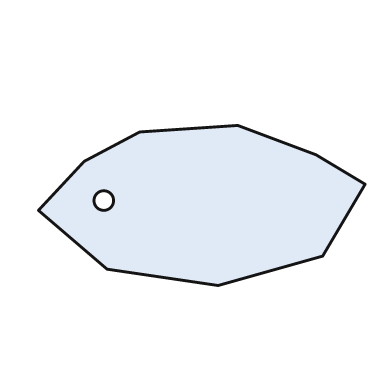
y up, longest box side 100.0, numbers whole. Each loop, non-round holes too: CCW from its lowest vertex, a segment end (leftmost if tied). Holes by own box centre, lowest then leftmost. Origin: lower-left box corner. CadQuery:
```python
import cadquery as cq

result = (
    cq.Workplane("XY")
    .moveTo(55.0, 0.0)
    .lineTo(87.0, 9.0)
    .lineTo(100.0, 31.0)
    .lineTo(85.0, 40.0)
    .lineTo(61.0, 49.0)
    .lineTo(31.0, 47.0)
    .lineTo(14.0, 38.0)
    .lineTo(0.0, 23.0)
    .lineTo(21.0, 5.0)
    .close()
    .moveTo(20.0, 26.0)
    .circle(3.0)
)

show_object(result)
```